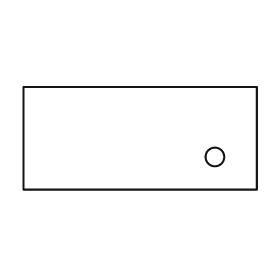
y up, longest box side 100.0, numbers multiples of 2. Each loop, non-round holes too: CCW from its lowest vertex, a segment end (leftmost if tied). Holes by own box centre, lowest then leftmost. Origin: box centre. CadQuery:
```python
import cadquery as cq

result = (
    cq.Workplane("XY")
    .moveTo(-50.0, -22.0)
    .lineTo(50.0, -22.0)
    .lineTo(50.0, 22.0)
    .lineTo(-50.0, 22.0)
    .close()
    .moveTo(32.0, -8.0)
    .circle(4.0)
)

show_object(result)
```